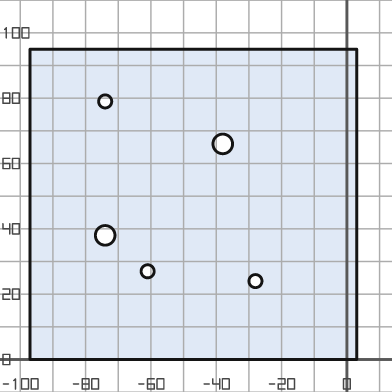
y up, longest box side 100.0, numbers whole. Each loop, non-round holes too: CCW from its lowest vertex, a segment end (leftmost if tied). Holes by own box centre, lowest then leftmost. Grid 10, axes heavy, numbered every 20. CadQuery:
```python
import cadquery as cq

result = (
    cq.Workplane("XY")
    .moveTo(-97.0, 0.0)
    .lineTo(3.0, 0.0)
    .lineTo(3.0, 95.0)
    .lineTo(-97.0, 95.0)
    .close()
    .moveTo(-28.0, 24.0)
    .circle(2.0)
    .moveTo(-61.0, 27.0)
    .circle(2.0)
    .moveTo(-74.0, 38.0)
    .circle(3.0)
    .moveTo(-38.0, 66.0)
    .circle(3.0)
    .moveTo(-74.0, 79.0)
    .circle(2.0)
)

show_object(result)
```